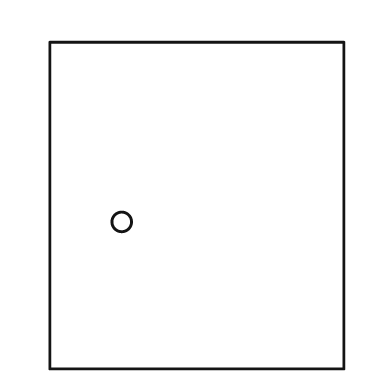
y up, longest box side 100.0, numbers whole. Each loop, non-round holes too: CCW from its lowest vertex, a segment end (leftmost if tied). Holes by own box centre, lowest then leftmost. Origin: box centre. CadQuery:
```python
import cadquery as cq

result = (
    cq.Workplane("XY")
    .moveTo(-45.0, -50.0)
    .lineTo(45.0, -50.0)
    .lineTo(45.0, 50.0)
    .lineTo(-45.0, 50.0)
    .close()
    .moveTo(-23.0, -5.0)
    .circle(3.0)
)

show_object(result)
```